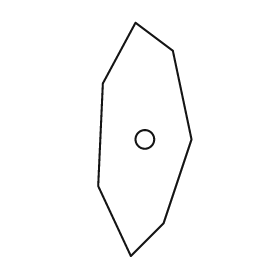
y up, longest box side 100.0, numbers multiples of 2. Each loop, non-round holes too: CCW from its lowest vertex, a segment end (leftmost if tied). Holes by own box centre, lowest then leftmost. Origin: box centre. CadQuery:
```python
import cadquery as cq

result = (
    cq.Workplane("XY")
    .moveTo(-6.0, -50.0)
    .lineTo(8.0, -36.0)
    .lineTo(20.0, 0.0)
    .lineTo(12.0, 38.0)
    .lineTo(-4.0, 50.0)
    .lineTo(-18.0, 24.0)
    .lineTo(-20.0, -20.0)
    .close()
    .moveTo(0.0, 0.0)
    .circle(4.0)
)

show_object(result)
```